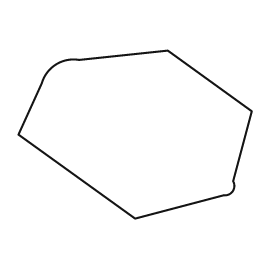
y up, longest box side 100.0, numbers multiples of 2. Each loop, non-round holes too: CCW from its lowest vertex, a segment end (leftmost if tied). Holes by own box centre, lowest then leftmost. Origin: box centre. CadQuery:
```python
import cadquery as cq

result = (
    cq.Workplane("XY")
    .moveTo(0.0, -36.0)
    .lineTo(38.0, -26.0)
    .threePointArc((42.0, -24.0), (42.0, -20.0))
    .lineTo(50.0, 10.0)
    .lineTo(14.0, 36.0)
    .lineTo(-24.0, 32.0)
    .threePointArc((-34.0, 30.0), (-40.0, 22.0))
    .lineTo(-50.0, 0.0)
    .close()
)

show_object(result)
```